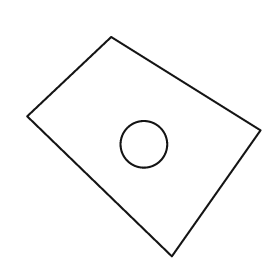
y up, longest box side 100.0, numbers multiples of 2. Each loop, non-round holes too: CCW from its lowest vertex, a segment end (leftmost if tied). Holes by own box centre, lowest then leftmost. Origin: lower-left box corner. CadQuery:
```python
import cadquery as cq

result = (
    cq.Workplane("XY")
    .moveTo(62.0, 0.0)
    .lineTo(100.0, 54.0)
    .lineTo(36.0, 94.0)
    .lineTo(0.0, 60.0)
    .close()
    .moveTo(50.0, 48.0)
    .circle(10.0)
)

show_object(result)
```